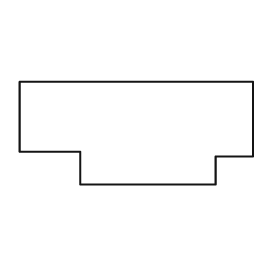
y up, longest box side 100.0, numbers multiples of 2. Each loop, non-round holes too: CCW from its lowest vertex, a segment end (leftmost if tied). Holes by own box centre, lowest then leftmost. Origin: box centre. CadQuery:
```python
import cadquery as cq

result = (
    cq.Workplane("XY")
    .moveTo(-24.0, -22.0)
    .lineTo(34.0, -22.0)
    .lineTo(34.0, -10.0)
    .lineTo(50.0, -10.0)
    .lineTo(50.0, 22.0)
    .lineTo(-50.0, 22.0)
    .lineTo(-50.0, -8.0)
    .lineTo(-24.0, -8.0)
    .close()
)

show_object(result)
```